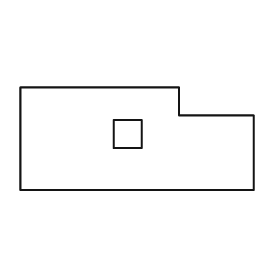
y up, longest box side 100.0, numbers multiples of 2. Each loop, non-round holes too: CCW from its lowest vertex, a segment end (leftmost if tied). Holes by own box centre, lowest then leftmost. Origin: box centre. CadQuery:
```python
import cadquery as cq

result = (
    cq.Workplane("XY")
    .moveTo(-50.0, -22.0)
    .lineTo(50.0, -22.0)
    .lineTo(50.0, 10.0)
    .lineTo(18.0, 10.0)
    .lineTo(18.0, 22.0)
    .lineTo(-50.0, 22.0)
    .close()
    .moveTo(-10.0, -4.0)
    .lineTo(2.0, -4.0)
    .lineTo(2.0, 8.0)
    .lineTo(-10.0, 8.0)
    .close()
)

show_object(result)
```